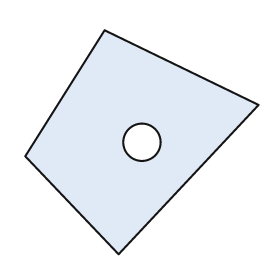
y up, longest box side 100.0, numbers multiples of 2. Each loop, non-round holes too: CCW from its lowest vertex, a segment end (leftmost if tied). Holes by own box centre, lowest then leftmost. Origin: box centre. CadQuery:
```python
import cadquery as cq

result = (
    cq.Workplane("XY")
    .moveTo(-10.0, -48.0)
    .lineTo(50.0, 16.0)
    .lineTo(-16.0, 48.0)
    .lineTo(-50.0, -6.0)
    .close()
    .moveTo(0.0, 0.0)
    .circle(8.0)
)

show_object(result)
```